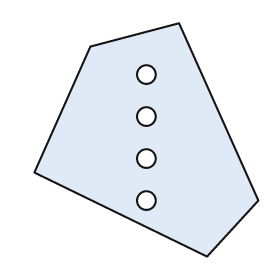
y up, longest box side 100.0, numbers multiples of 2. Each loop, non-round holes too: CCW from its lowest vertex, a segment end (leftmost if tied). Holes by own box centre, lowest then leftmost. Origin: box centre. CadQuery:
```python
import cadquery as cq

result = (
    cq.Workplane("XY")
    .moveTo(26.0, -50.0)
    .lineTo(48.0, -26.0)
    .lineTo(14.0, 50.0)
    .lineTo(-24.0, 40.0)
    .lineTo(-48.0, -14.0)
    .close()
    .moveTo(0.0, -26.0)
    .circle(4.0)
    .moveTo(0.0, -8.0)
    .circle(4.0)
    .moveTo(0.0, 10.0)
    .circle(4.0)
    .moveTo(0.0, 28.0)
    .circle(4.0)
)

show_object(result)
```